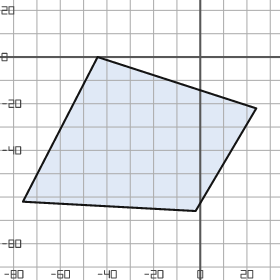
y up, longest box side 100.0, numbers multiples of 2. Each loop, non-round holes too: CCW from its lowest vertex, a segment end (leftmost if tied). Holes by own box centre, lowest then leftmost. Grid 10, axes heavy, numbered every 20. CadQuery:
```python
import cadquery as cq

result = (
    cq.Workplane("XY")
    .moveTo(-2.0, -66.0)
    .lineTo(24.0, -22.0)
    .lineTo(-44.0, 0.0)
    .lineTo(-76.0, -62.0)
    .close()
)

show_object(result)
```